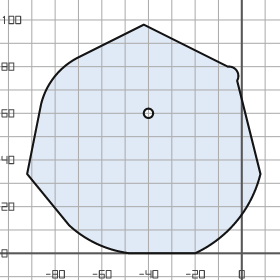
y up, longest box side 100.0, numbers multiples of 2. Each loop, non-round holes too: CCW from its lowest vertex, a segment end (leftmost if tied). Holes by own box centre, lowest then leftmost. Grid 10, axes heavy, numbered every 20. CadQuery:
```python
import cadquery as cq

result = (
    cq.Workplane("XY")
    .moveTo(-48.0, 0.0)
    .lineTo(-20.0, 0.0)
    .threePointArc((-2.0, 14.0), (8.0, 34.0))
    .lineTo(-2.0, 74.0)
    .threePointArc((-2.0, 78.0), (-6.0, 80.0))
    .lineTo(-42.0, 98.0)
    .lineTo(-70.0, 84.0)
    .threePointArc((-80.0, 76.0), (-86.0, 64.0))
    .lineTo(-92.0, 34.0)
    .lineTo(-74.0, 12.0)
    .threePointArc((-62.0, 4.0), (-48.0, 0.0))
    .close()
    .moveTo(-40.0, 60.0)
    .circle(2.0)
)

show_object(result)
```